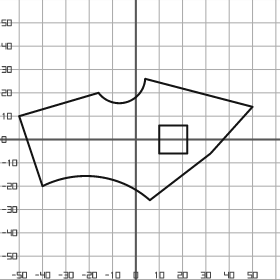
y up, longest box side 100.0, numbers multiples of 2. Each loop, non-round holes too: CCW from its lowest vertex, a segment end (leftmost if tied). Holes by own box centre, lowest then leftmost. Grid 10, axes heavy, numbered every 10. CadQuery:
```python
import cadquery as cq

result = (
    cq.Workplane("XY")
    .moveTo(6.0, -26.0)
    .lineTo(32.0, -6.0)
    .lineTo(50.0, 14.0)
    .lineTo(4.0, 26.0)
    .threePointArc((-4.0, 16.0), (-16.0, 20.0))
    .lineTo(-50.0, 10.0)
    .lineTo(-40.0, -20.0)
    .threePointArc((-16.0, -16.0), (6.0, -26.0))
    .close()
    .moveTo(10.0, -6.0)
    .lineTo(22.0, -6.0)
    .lineTo(22.0, 6.0)
    .lineTo(10.0, 6.0)
    .close()
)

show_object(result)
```